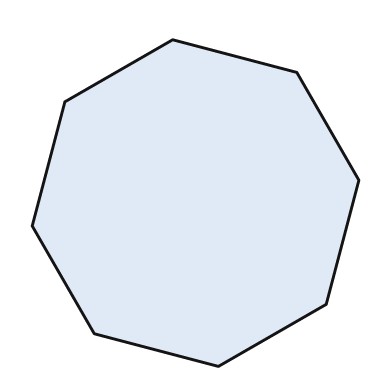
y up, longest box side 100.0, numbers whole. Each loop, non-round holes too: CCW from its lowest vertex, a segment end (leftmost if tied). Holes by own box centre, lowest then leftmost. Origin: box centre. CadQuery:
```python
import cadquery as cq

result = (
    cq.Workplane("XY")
    .moveTo(7.0, -50.0)
    .lineTo(40.0, -31.0)
    .lineTo(50.0, 7.0)
    .lineTo(31.0, 40.0)
    .lineTo(-7.0, 50.0)
    .lineTo(-40.0, 31.0)
    .lineTo(-50.0, -7.0)
    .lineTo(-31.0, -40.0)
    .close()
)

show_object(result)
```